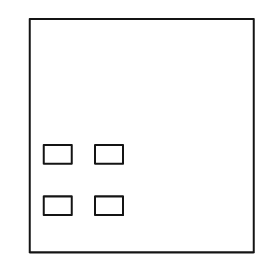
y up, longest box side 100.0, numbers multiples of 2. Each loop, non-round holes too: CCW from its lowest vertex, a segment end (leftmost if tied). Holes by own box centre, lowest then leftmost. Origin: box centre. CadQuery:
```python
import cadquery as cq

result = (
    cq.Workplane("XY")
    .moveTo(-48.0, -50.0)
    .lineTo(48.0, -50.0)
    .lineTo(48.0, 50.0)
    .lineTo(-48.0, 50.0)
    .close()
    .moveTo(-42.0, -34.0)
    .lineTo(-30.0, -34.0)
    .lineTo(-30.0, -26.0)
    .lineTo(-42.0, -26.0)
    .close()
    .moveTo(-20.0, -34.0)
    .lineTo(-8.0, -34.0)
    .lineTo(-8.0, -26.0)
    .lineTo(-20.0, -26.0)
    .close()
    .moveTo(-42.0, -12.0)
    .lineTo(-30.0, -12.0)
    .lineTo(-30.0, -4.0)
    .lineTo(-42.0, -4.0)
    .close()
    .moveTo(-20.0, -12.0)
    .lineTo(-8.0, -12.0)
    .lineTo(-8.0, -4.0)
    .lineTo(-20.0, -4.0)
    .close()
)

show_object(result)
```